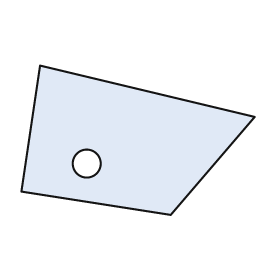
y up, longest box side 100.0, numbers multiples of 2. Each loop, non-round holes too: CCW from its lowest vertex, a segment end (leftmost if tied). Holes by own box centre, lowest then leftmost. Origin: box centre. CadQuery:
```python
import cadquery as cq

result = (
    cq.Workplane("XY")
    .moveTo(14.0, -32.0)
    .lineTo(50.0, 10.0)
    .lineTo(-42.0, 32.0)
    .lineTo(-50.0, -22.0)
    .close()
    .moveTo(-22.0, -10.0)
    .circle(6.0)
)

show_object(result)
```